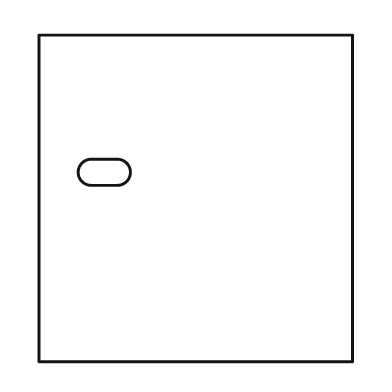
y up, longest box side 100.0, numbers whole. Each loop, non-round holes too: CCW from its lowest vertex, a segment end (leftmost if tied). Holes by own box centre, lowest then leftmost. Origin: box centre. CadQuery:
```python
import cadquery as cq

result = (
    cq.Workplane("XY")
    .moveTo(-48.0, -50.0)
    .lineTo(48.0, -50.0)
    .lineTo(48.0, 50.0)
    .lineTo(-48.0, 50.0)
    .close()
    .moveTo(-32.0, 4.0)
    .lineTo(-24.0, 4.0)
    .threePointArc((-20.0, 8.0), (-24.0, 12.0))
    .lineTo(-32.0, 12.0)
    .threePointArc((-36.0, 8.0), (-32.0, 4.0))
    .close()
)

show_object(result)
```